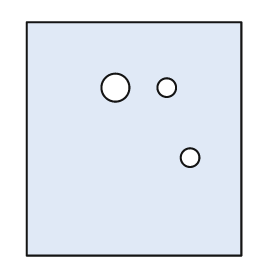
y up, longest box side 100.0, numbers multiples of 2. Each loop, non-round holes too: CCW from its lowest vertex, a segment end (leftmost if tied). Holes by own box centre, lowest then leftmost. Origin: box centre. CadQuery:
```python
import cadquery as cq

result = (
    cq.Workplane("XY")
    .moveTo(-46.0, -50.0)
    .lineTo(46.0, -50.0)
    .lineTo(46.0, 50.0)
    .lineTo(-46.0, 50.0)
    .close()
    .moveTo(24.0, -8.0)
    .circle(4.0)
    .moveTo(-8.0, 22.0)
    .circle(6.0)
    .moveTo(14.0, 22.0)
    .circle(4.0)
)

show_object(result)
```